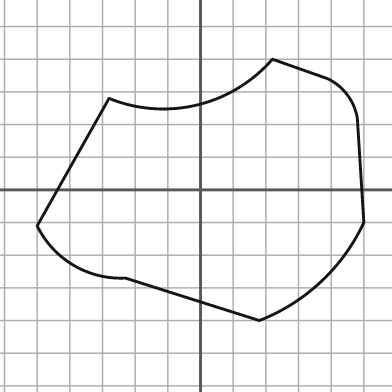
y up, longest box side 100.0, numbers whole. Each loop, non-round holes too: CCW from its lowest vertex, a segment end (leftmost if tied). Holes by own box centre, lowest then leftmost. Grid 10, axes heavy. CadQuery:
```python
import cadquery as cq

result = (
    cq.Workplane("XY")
    .moveTo(18.0, -40.0)
    .threePointArc((37.0, -28.0), (50.0, -10.0))
    .lineTo(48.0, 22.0)
    .threePointArc((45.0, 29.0), (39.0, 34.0))
    .lineTo(22.0, 40.0)
    .threePointArc((-1.0, 26.0), (-28.0, 28.0))
    .lineTo(-50.0, -11.0)
    .threePointArc((-39.0, -23.0), (-23.0, -27.0))
    .close()
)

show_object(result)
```